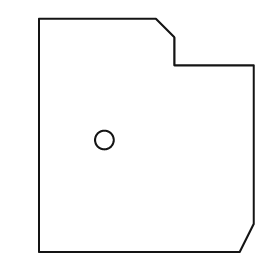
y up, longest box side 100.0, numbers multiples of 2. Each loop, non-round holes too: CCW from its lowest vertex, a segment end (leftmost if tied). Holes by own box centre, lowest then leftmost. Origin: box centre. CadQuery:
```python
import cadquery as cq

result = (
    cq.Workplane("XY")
    .moveTo(-46.0, -50.0)
    .lineTo(40.0, -50.0)
    .lineTo(46.0, -38.0)
    .lineTo(46.0, 30.0)
    .lineTo(12.0, 30.0)
    .lineTo(12.0, 42.0)
    .lineTo(4.0, 50.0)
    .lineTo(-46.0, 50.0)
    .close()
    .moveTo(-18.0, -2.0)
    .circle(4.0)
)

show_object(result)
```